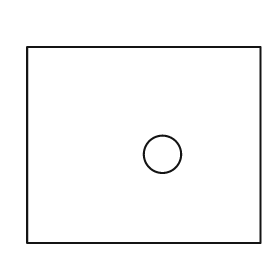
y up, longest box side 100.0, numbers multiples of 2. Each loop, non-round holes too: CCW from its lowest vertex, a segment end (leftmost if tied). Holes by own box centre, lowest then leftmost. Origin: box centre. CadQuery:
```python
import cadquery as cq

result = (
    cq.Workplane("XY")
    .moveTo(-50.0, -42.0)
    .lineTo(50.0, -42.0)
    .lineTo(50.0, 42.0)
    .lineTo(-50.0, 42.0)
    .close()
    .moveTo(8.0, -4.0)
    .circle(8.0)
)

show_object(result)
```